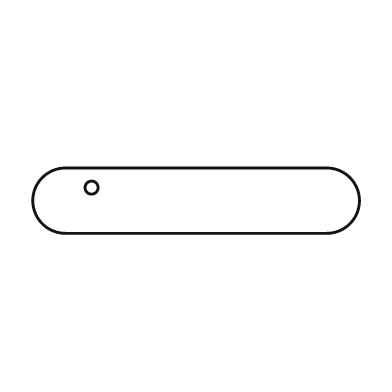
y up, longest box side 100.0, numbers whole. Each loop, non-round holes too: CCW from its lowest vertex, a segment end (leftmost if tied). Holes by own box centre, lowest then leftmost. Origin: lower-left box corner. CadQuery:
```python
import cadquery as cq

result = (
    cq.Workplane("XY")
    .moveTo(10.0, 0.0)
    .lineTo(90.0, 0.0)
    .threePointArc((100.0, 10.0), (90.0, 20.0))
    .lineTo(10.0, 20.0)
    .threePointArc((0.0, 10.0), (10.0, 0.0))
    .close()
    .moveTo(18.0, 14.0)
    .circle(2.0)
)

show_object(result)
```